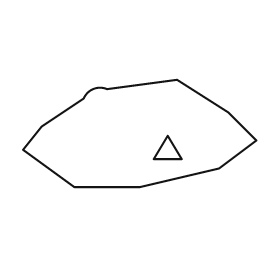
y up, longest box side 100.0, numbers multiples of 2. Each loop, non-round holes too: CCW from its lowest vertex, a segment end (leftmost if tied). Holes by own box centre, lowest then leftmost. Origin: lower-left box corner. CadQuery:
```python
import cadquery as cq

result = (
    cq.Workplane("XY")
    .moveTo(22.0, 0.0)
    .lineTo(50.0, 0.0)
    .lineTo(84.0, 8.0)
    .lineTo(100.0, 20.0)
    .lineTo(88.0, 32.0)
    .lineTo(66.0, 46.0)
    .lineTo(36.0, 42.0)
    .threePointArc((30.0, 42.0), (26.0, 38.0))
    .lineTo(8.0, 26.0)
    .lineTo(0.0, 16.0)
    .close()
    .moveTo(56.0, 12.0)
    .lineTo(68.0, 12.0)
    .lineTo(62.0, 22.0)
    .close()
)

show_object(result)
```